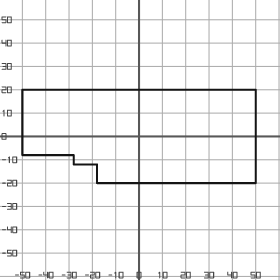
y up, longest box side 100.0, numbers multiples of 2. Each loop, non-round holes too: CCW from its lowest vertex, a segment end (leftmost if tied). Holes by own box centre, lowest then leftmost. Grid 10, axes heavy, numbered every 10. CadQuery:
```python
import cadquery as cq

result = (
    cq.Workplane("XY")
    .moveTo(-18.0, -20.0)
    .lineTo(50.0, -20.0)
    .lineTo(50.0, 20.0)
    .lineTo(-50.0, 20.0)
    .lineTo(-50.0, -8.0)
    .lineTo(-28.0, -8.0)
    .lineTo(-28.0, -12.0)
    .lineTo(-18.0, -12.0)
    .close()
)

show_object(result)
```